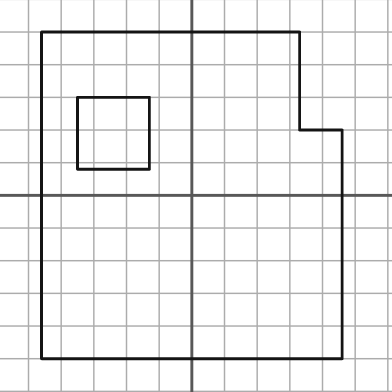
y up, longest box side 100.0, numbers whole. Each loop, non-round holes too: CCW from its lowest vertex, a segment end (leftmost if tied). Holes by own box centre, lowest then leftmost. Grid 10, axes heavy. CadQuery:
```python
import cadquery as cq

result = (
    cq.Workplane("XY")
    .moveTo(-46.0, -50.0)
    .lineTo(46.0, -50.0)
    .lineTo(46.0, 20.0)
    .lineTo(33.0, 20.0)
    .lineTo(33.0, 50.0)
    .lineTo(-46.0, 50.0)
    .close()
    .moveTo(-35.0, 8.0)
    .lineTo(-13.0, 8.0)
    .lineTo(-13.0, 30.0)
    .lineTo(-35.0, 30.0)
    .close()
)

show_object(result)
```